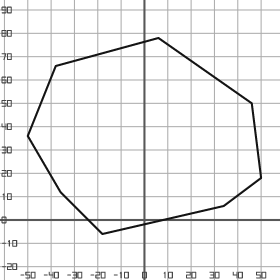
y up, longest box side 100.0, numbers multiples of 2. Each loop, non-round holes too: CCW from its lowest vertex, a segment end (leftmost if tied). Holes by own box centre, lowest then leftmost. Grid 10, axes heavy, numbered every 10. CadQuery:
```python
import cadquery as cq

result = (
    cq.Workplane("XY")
    .moveTo(-18.0, -6.0)
    .lineTo(34.0, 6.0)
    .lineTo(50.0, 18.0)
    .lineTo(46.0, 50.0)
    .lineTo(6.0, 78.0)
    .lineTo(-38.0, 66.0)
    .lineTo(-50.0, 36.0)
    .lineTo(-36.0, 12.0)
    .close()
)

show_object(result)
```